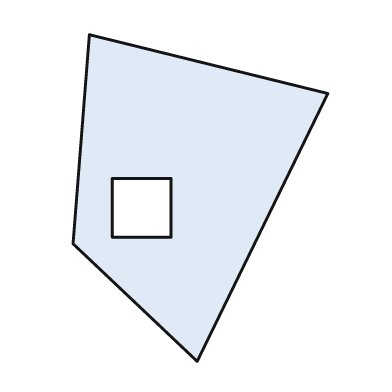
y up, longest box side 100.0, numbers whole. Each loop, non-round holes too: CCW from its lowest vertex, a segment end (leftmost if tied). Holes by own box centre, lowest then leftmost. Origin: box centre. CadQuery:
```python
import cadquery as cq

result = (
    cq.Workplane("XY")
    .moveTo(-1.0, -50.0)
    .lineTo(39.0, 32.0)
    .lineTo(-34.0, 50.0)
    .lineTo(-39.0, -14.0)
    .close()
    .moveTo(-27.0, -12.0)
    .lineTo(-9.0, -12.0)
    .lineTo(-9.0, 6.0)
    .lineTo(-27.0, 6.0)
    .close()
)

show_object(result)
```